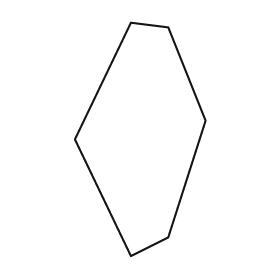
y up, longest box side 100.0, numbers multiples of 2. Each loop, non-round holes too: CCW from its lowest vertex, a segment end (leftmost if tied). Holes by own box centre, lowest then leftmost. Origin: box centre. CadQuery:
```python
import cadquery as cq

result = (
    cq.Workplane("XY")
    .moveTo(-4.0, -50.0)
    .lineTo(12.0, -42.0)
    .lineTo(28.0, 8.0)
    .lineTo(12.0, 48.0)
    .lineTo(-4.0, 50.0)
    .lineTo(-28.0, 0.0)
    .close()
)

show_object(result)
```